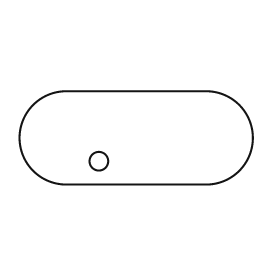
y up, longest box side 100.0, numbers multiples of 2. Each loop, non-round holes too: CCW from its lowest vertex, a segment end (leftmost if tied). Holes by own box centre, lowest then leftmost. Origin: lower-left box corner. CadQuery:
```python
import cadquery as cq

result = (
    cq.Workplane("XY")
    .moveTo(20.0, 0.0)
    .lineTo(80.0, 0.0)
    .threePointArc((100.0, 20.0), (80.0, 40.0))
    .lineTo(20.0, 40.0)
    .threePointArc((0.0, 20.0), (20.0, 0.0))
    .close()
    .moveTo(34.0, 10.0)
    .circle(4.0)
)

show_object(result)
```